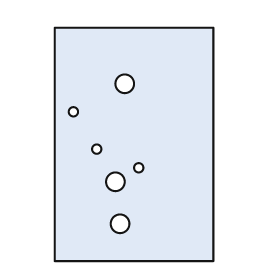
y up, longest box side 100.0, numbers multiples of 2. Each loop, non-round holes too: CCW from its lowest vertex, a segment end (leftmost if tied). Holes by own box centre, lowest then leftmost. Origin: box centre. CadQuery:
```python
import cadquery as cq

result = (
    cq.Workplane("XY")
    .moveTo(-34.0, -50.0)
    .lineTo(34.0, -50.0)
    .lineTo(34.0, 50.0)
    .lineTo(-34.0, 50.0)
    .close()
    .moveTo(-6.0, -34.0)
    .circle(4.0)
    .moveTo(-8.0, -16.0)
    .circle(4.0)
    .moveTo(2.0, -10.0)
    .circle(2.0)
    .moveTo(-16.0, -2.0)
    .circle(2.0)
    .moveTo(-26.0, 14.0)
    .circle(2.0)
    .moveTo(-4.0, 26.0)
    .circle(4.0)
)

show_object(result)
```